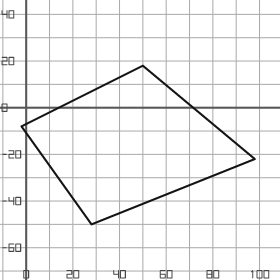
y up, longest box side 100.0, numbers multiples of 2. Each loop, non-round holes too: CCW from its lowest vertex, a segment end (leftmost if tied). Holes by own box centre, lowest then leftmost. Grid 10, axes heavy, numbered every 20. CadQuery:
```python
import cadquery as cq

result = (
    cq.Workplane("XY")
    .moveTo(28.0, -50.0)
    .lineTo(98.0, -22.0)
    .lineTo(50.0, 18.0)
    .lineTo(-2.0, -8.0)
    .close()
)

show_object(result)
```